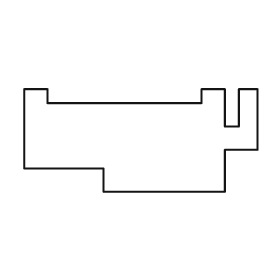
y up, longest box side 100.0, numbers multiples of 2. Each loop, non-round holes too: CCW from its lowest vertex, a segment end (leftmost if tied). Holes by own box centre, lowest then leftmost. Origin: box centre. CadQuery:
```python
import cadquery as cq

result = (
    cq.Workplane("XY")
    .moveTo(-16.0, -22.0)
    .lineTo(36.0, -22.0)
    .lineTo(36.0, -4.0)
    .lineTo(50.0, -4.0)
    .lineTo(50.0, 22.0)
    .lineTo(42.0, 22.0)
    .lineTo(42.0, 6.0)
    .lineTo(36.0, 6.0)
    .lineTo(36.0, 22.0)
    .lineTo(26.0, 22.0)
    .lineTo(26.0, 16.0)
    .lineTo(-40.0, 16.0)
    .lineTo(-40.0, 22.0)
    .lineTo(-50.0, 22.0)
    .lineTo(-50.0, -12.0)
    .lineTo(-16.0, -12.0)
    .close()
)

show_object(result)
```